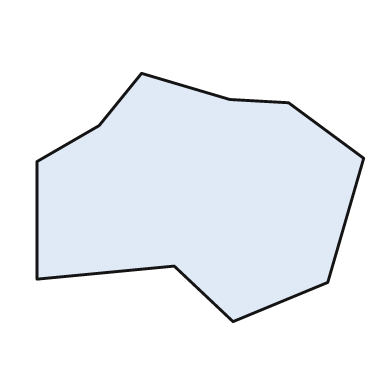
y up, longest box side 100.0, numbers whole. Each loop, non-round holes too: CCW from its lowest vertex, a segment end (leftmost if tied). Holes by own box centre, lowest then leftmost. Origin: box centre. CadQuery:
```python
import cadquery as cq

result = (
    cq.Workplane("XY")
    .moveTo(10.0, -38.0)
    .lineTo(39.0, -26.0)
    .lineTo(50.0, 12.0)
    .lineTo(27.0, 29.0)
    .lineTo(9.0, 30.0)
    .lineTo(-18.0, 38.0)
    .lineTo(-31.0, 22.0)
    .lineTo(-50.0, 11.0)
    .lineTo(-50.0, -25.0)
    .lineTo(-8.0, -21.0)
    .close()
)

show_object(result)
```